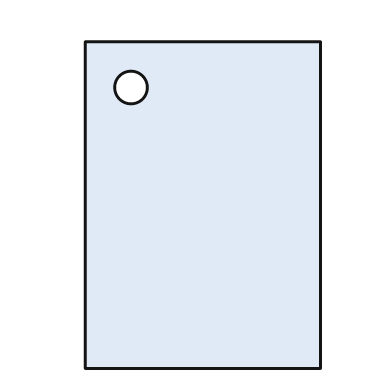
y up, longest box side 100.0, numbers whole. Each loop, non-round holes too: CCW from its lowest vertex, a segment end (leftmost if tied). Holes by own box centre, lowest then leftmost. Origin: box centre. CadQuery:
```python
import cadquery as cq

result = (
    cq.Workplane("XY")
    .moveTo(-36.0, -50.0)
    .lineTo(36.0, -50.0)
    .lineTo(36.0, 50.0)
    .lineTo(-36.0, 50.0)
    .close()
    .moveTo(-22.0, 36.0)
    .circle(5.0)
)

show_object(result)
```